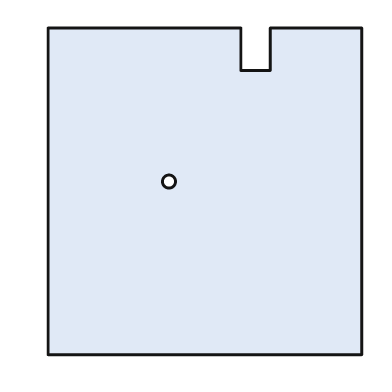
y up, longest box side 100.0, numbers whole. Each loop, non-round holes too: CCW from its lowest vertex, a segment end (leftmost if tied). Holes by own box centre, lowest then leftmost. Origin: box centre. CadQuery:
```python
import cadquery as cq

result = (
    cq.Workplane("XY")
    .moveTo(-48.0, -50.0)
    .lineTo(48.0, -50.0)
    .lineTo(48.0, 50.0)
    .lineTo(20.0, 50.0)
    .lineTo(20.0, 37.0)
    .lineTo(11.0, 37.0)
    .lineTo(11.0, 50.0)
    .lineTo(-48.0, 50.0)
    .close()
    .moveTo(-11.0, 3.0)
    .circle(2.0)
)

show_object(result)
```